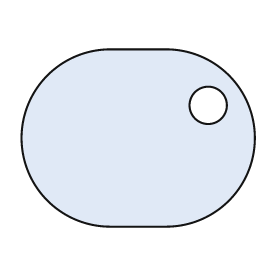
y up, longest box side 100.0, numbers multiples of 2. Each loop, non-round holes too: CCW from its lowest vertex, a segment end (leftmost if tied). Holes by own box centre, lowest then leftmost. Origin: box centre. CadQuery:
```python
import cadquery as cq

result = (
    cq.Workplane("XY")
    .moveTo(-12.0, -38.0)
    .lineTo(12.0, -38.0)
    .threePointArc((50.0, 0.0), (12.0, 38.0))
    .lineTo(-12.0, 38.0)
    .threePointArc((-50.0, 0.0), (-12.0, -38.0))
    .close()
    .moveTo(30.0, 14.0)
    .circle(8.0)
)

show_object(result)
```